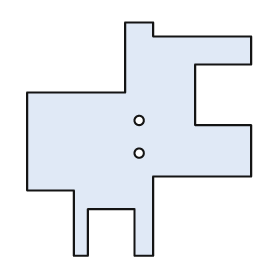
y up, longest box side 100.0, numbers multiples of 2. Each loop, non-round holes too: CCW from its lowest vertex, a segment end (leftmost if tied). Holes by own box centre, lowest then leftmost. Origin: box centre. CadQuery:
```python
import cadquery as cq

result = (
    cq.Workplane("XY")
    .moveTo(-28.0, -50.0)
    .lineTo(-22.0, -50.0)
    .lineTo(-22.0, -30.0)
    .lineTo(-2.0, -30.0)
    .lineTo(-2.0, -50.0)
    .lineTo(6.0, -50.0)
    .lineTo(6.0, -16.0)
    .lineTo(48.0, -16.0)
    .lineTo(48.0, 6.0)
    .lineTo(24.0, 6.0)
    .lineTo(24.0, 32.0)
    .lineTo(48.0, 32.0)
    .lineTo(48.0, 44.0)
    .lineTo(6.0, 44.0)
    .lineTo(6.0, 50.0)
    .lineTo(-6.0, 50.0)
    .lineTo(-6.0, 20.0)
    .lineTo(-48.0, 20.0)
    .lineTo(-48.0, -22.0)
    .lineTo(-28.0, -22.0)
    .close()
    .moveTo(0.0, -6.0)
    .circle(2.0)
    .moveTo(0.0, 8.0)
    .circle(2.0)
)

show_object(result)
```